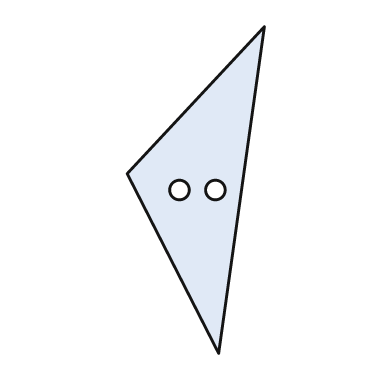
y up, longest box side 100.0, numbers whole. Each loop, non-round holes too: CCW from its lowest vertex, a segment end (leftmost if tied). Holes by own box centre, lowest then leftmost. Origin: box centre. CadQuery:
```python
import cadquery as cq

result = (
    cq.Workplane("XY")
    .moveTo(7.0, -50.0)
    .lineTo(21.0, 50.0)
    .lineTo(-21.0, 5.0)
    .close()
    .moveTo(-5.0, 0.0)
    .circle(3.0)
    .moveTo(6.0, 0.0)
    .circle(3.0)
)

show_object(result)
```